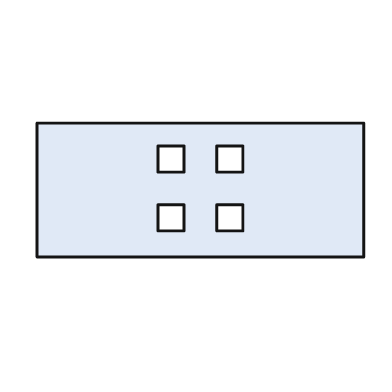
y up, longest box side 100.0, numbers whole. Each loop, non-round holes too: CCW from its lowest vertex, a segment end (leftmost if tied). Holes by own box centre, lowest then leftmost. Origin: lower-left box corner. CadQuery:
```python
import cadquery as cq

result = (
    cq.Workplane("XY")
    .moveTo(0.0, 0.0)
    .lineTo(100.0, 0.0)
    .lineTo(100.0, 41.0)
    .lineTo(0.0, 41.0)
    .close()
    .moveTo(37.0, 8.0)
    .lineTo(45.0, 8.0)
    .lineTo(45.0, 16.0)
    .lineTo(37.0, 16.0)
    .close()
    .moveTo(55.0, 8.0)
    .lineTo(63.0, 8.0)
    .lineTo(63.0, 16.0)
    .lineTo(55.0, 16.0)
    .close()
    .moveTo(37.0, 26.0)
    .lineTo(45.0, 26.0)
    .lineTo(45.0, 34.0)
    .lineTo(37.0, 34.0)
    .close()
    .moveTo(55.0, 26.0)
    .lineTo(63.0, 26.0)
    .lineTo(63.0, 34.0)
    .lineTo(55.0, 34.0)
    .close()
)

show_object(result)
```